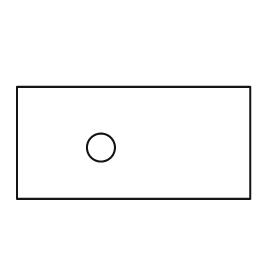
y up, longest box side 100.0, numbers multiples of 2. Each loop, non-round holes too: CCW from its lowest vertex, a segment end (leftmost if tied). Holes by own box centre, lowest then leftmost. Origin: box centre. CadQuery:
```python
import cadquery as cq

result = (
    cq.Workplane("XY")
    .moveTo(-50.0, -24.0)
    .lineTo(50.0, -24.0)
    .lineTo(50.0, 24.0)
    .lineTo(-50.0, 24.0)
    .close()
    .moveTo(-14.0, -2.0)
    .circle(6.0)
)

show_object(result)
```